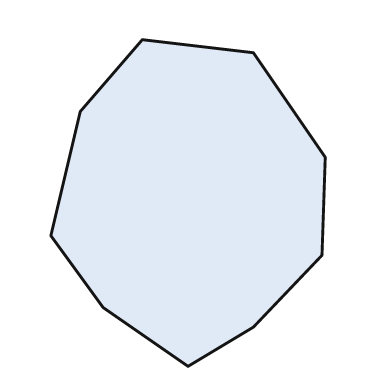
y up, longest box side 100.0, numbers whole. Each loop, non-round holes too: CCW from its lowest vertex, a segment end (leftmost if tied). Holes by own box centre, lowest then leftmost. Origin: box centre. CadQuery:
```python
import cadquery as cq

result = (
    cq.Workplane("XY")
    .moveTo(0.0, -50.0)
    .lineTo(20.0, -38.0)
    .lineTo(41.0, -16.0)
    .lineTo(42.0, 14.0)
    .lineTo(20.0, 46.0)
    .lineTo(-14.0, 50.0)
    .lineTo(-33.0, 28.0)
    .lineTo(-42.0, -10.0)
    .lineTo(-26.0, -32.0)
    .close()
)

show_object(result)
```